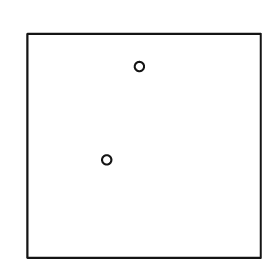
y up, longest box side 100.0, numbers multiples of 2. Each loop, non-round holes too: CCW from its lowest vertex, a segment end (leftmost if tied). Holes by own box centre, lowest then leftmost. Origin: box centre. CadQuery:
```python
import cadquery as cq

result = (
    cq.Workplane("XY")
    .moveTo(-50.0, -48.0)
    .lineTo(50.0, -48.0)
    .lineTo(50.0, 48.0)
    .lineTo(-50.0, 48.0)
    .close()
    .moveTo(-16.0, -6.0)
    .circle(2.0)
    .moveTo(-2.0, 34.0)
    .circle(2.0)
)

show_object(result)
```